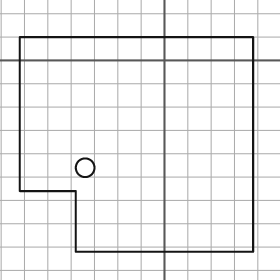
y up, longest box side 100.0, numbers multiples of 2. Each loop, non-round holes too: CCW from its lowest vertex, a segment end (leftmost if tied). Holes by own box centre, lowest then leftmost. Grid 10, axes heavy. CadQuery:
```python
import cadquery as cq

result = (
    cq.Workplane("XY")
    .moveTo(-38.0, -82.0)
    .lineTo(38.0, -82.0)
    .lineTo(38.0, 10.0)
    .lineTo(-62.0, 10.0)
    .lineTo(-62.0, -56.0)
    .lineTo(-38.0, -56.0)
    .close()
    .moveTo(-34.0, -46.0)
    .circle(4.0)
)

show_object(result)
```